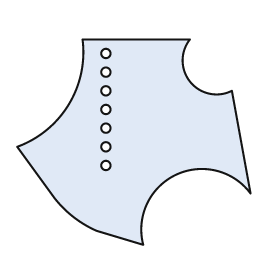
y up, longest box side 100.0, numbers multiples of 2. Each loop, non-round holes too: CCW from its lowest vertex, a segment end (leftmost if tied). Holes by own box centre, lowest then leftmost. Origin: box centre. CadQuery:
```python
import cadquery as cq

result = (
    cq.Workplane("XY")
    .moveTo(4.0, -44.0)
    .threePointArc((18.0, -14.0), (50.0, -22.0))
    .lineTo(42.0, 22.0)
    .threePointArc((24.0, 26.0), (24.0, 44.0))
    .lineTo(-22.0, 44.0)
    .threePointArc((-28.0, 16.0), (-50.0, -2.0))
    .lineTo(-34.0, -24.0)
    .threePointArc((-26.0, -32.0), (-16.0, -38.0))
    .close()
    .moveTo(-12.0, -10.0)
    .circle(2.0)
    .moveTo(-12.0, -2.0)
    .circle(2.0)
    .moveTo(-12.0, 6.0)
    .circle(2.0)
    .moveTo(-12.0, 14.0)
    .circle(2.0)
    .moveTo(-12.0, 22.0)
    .circle(2.0)
    .moveTo(-12.0, 30.0)
    .circle(2.0)
    .moveTo(-12.0, 38.0)
    .circle(2.0)
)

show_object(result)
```